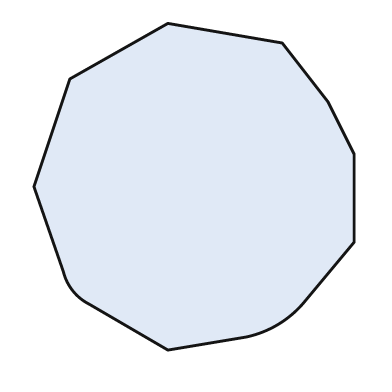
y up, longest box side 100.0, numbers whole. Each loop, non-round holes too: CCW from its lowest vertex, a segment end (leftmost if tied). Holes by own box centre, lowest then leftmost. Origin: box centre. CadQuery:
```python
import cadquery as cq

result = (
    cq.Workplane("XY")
    .moveTo(-8.0, -50.0)
    .lineTo(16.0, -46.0)
    .threePointArc((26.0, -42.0), (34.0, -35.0))
    .lineTo(49.0, -17.0)
    .lineTo(49.0, 10.0)
    .lineTo(41.0, 26.0)
    .lineTo(27.0, 44.0)
    .lineTo(-8.0, 50.0)
    .lineTo(-38.0, 33.0)
    .lineTo(-49.0, 0.0)
    .lineTo(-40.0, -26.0)
    .threePointArc((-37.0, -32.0), (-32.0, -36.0))
    .close()
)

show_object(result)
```